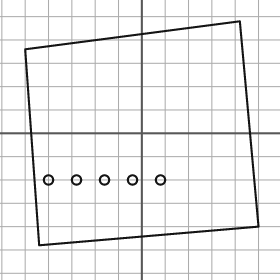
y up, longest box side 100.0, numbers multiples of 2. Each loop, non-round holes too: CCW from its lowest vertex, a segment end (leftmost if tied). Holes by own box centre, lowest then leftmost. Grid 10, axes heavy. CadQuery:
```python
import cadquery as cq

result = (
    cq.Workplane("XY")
    .moveTo(-44.0, -48.0)
    .lineTo(50.0, -40.0)
    .lineTo(42.0, 48.0)
    .lineTo(-50.0, 36.0)
    .close()
    .moveTo(-40.0, -20.0)
    .circle(2.0)
    .moveTo(-28.0, -20.0)
    .circle(2.0)
    .moveTo(-16.0, -20.0)
    .circle(2.0)
    .moveTo(-4.0, -20.0)
    .circle(2.0)
    .moveTo(8.0, -20.0)
    .circle(2.0)
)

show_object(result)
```